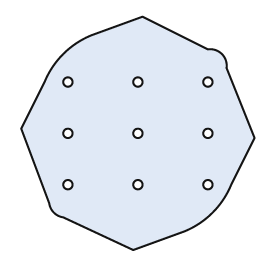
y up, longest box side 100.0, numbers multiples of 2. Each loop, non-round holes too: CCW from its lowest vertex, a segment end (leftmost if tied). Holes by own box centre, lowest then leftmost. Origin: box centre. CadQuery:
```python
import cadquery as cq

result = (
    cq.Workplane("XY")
    .moveTo(-2.0, -50.0)
    .lineTo(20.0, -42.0)
    .threePointArc((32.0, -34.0), (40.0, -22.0))
    .lineTo(50.0, -2.0)
    .lineTo(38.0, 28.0)
    .threePointArc((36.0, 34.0), (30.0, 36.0))
    .lineTo(2.0, 50.0)
    .lineTo(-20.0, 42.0)
    .threePointArc((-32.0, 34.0), (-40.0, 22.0))
    .lineTo(-50.0, 2.0)
    .lineTo(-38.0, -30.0)
    .threePointArc((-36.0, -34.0), (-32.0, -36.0))
    .close()
    .moveTo(-30.0, -22.0)
    .circle(2.0)
    .moveTo(0.0, -22.0)
    .circle(2.0)
    .moveTo(30.0, -22.0)
    .circle(2.0)
    .moveTo(-30.0, 0.0)
    .circle(2.0)
    .moveTo(0.0, 0.0)
    .circle(2.0)
    .moveTo(30.0, 0.0)
    .circle(2.0)
    .moveTo(-30.0, 22.0)
    .circle(2.0)
    .moveTo(0.0, 22.0)
    .circle(2.0)
    .moveTo(30.0, 22.0)
    .circle(2.0)
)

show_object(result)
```